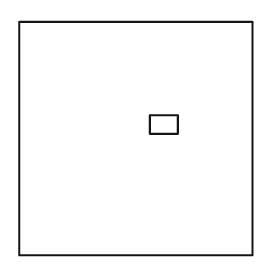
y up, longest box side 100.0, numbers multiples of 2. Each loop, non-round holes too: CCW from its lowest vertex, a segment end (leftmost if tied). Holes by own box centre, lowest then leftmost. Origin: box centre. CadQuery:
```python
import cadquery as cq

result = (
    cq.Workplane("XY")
    .moveTo(-50.0, -50.0)
    .lineTo(50.0, -50.0)
    .lineTo(50.0, 50.0)
    .lineTo(-50.0, 50.0)
    .close()
    .moveTo(6.0, 2.0)
    .lineTo(18.0, 2.0)
    .lineTo(18.0, 10.0)
    .lineTo(6.0, 10.0)
    .close()
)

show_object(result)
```